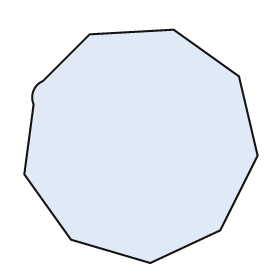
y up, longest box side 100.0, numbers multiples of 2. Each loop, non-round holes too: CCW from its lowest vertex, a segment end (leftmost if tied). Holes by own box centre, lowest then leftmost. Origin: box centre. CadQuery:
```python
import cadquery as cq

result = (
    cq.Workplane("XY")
    .moveTo(4.0, -50.0)
    .lineTo(34.0, -36.0)
    .lineTo(50.0, -4.0)
    .lineTo(42.0, 30.0)
    .lineTo(14.0, 50.0)
    .lineTo(-22.0, 48.0)
    .lineTo(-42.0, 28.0)
    .threePointArc((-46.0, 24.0), (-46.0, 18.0))
    .lineTo(-50.0, -12.0)
    .lineTo(-30.0, -40.0)
    .close()
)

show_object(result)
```